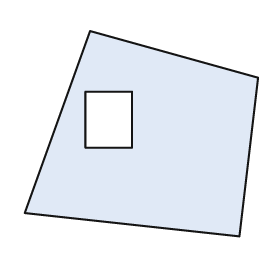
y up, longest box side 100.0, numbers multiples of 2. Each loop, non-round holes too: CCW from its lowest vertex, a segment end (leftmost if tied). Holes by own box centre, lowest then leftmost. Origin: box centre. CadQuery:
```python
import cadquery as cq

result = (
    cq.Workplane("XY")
    .moveTo(42.0, -44.0)
    .lineTo(50.0, 24.0)
    .lineTo(-22.0, 44.0)
    .lineTo(-50.0, -34.0)
    .close()
    .moveTo(-24.0, -6.0)
    .lineTo(-4.0, -6.0)
    .lineTo(-4.0, 18.0)
    .lineTo(-24.0, 18.0)
    .close()
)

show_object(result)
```